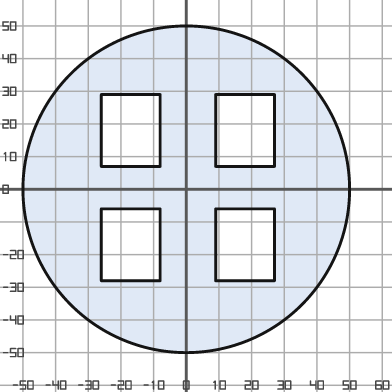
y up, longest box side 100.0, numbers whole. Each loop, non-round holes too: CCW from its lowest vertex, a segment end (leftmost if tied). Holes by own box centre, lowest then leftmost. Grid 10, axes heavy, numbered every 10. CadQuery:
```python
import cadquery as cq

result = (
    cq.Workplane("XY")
    .moveTo(0.0, 0.0)
    .circle(50.0)
    .moveTo(-26.0, -28.0)
    .lineTo(-8.0, -28.0)
    .lineTo(-8.0, -6.0)
    .lineTo(-26.0, -6.0)
    .close()
    .moveTo(9.0, -28.0)
    .lineTo(27.0, -28.0)
    .lineTo(27.0, -6.0)
    .lineTo(9.0, -6.0)
    .close()
    .moveTo(-26.0, 7.0)
    .lineTo(-8.0, 7.0)
    .lineTo(-8.0, 29.0)
    .lineTo(-26.0, 29.0)
    .close()
    .moveTo(9.0, 7.0)
    .lineTo(27.0, 7.0)
    .lineTo(27.0, 29.0)
    .lineTo(9.0, 29.0)
    .close()
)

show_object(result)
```